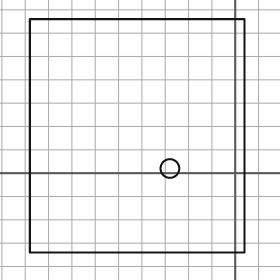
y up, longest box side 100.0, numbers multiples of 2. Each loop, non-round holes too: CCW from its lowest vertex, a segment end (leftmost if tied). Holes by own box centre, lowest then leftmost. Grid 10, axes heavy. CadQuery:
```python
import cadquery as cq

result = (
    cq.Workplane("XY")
    .moveTo(-88.0, -34.0)
    .lineTo(4.0, -34.0)
    .lineTo(4.0, 66.0)
    .lineTo(-88.0, 66.0)
    .close()
    .moveTo(-28.0, 2.0)
    .circle(4.0)
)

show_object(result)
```